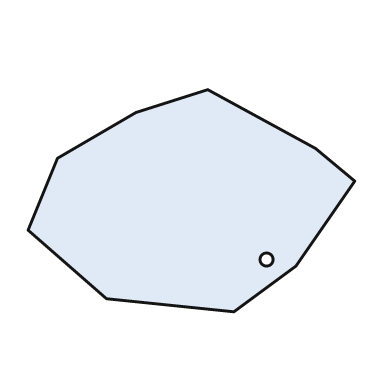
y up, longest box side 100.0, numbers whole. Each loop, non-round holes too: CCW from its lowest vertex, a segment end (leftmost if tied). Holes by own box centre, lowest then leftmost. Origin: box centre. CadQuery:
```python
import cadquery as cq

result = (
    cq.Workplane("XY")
    .moveTo(13.0, -34.0)
    .lineTo(32.0, -20.0)
    .lineTo(50.0, 6.0)
    .lineTo(38.0, 16.0)
    .lineTo(5.0, 34.0)
    .lineTo(-17.0, 27.0)
    .lineTo(-41.0, 13.0)
    .lineTo(-50.0, -9.0)
    .lineTo(-26.0, -30.0)
    .close()
    .moveTo(23.0, -18.0)
    .circle(2.0)
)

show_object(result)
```